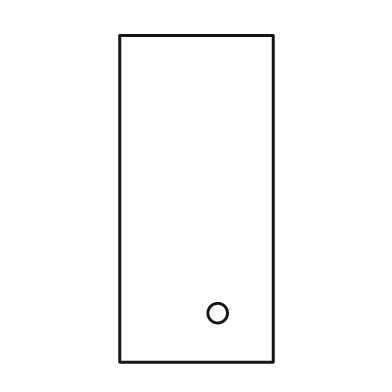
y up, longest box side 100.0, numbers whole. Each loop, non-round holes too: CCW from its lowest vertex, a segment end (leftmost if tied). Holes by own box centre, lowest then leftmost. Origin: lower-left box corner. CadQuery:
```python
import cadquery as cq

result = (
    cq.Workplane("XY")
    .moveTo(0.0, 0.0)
    .lineTo(47.0, 0.0)
    .lineTo(47.0, 100.0)
    .lineTo(0.0, 100.0)
    .close()
    .moveTo(30.0, 15.0)
    .circle(3.0)
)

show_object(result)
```